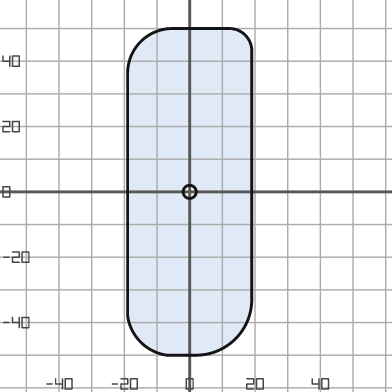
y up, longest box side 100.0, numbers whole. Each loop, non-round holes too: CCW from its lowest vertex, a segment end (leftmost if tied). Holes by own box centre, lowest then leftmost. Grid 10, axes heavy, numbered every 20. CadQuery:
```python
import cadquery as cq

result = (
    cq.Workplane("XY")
    .moveTo(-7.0, -50.0)
    .lineTo(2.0, -50.0)
    .threePointArc((14.0, -45.0), (19.0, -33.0))
    .lineTo(19.0, 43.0)
    .threePointArc((17.0, 48.0), (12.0, 50.0))
    .lineTo(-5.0, 50.0)
    .threePointArc((-15.0, 46.0), (-19.0, 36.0))
    .lineTo(-19.0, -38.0)
    .threePointArc((-15.0, -46.0), (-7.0, -50.0))
    .close()
    .moveTo(0.0, 0.0)
    .circle(2.0)
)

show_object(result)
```